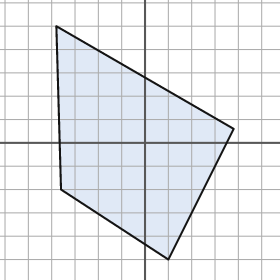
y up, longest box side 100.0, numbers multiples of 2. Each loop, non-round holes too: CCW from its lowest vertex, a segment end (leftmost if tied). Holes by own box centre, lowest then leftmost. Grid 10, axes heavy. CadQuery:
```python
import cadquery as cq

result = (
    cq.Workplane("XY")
    .moveTo(10.0, -50.0)
    .lineTo(38.0, 6.0)
    .lineTo(-38.0, 50.0)
    .lineTo(-36.0, -20.0)
    .close()
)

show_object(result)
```